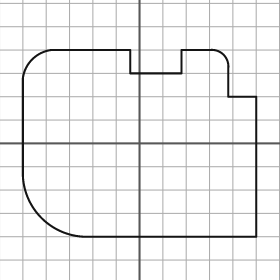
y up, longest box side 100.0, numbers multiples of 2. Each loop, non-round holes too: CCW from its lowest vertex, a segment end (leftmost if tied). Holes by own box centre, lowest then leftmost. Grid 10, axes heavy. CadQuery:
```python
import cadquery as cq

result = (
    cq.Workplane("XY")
    .moveTo(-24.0, -40.0)
    .lineTo(50.0, -40.0)
    .lineTo(50.0, 20.0)
    .lineTo(38.0, 20.0)
    .lineTo(38.0, 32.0)
    .threePointArc((36.0, 38.0), (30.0, 40.0))
    .lineTo(18.0, 40.0)
    .lineTo(18.0, 30.0)
    .lineTo(-4.0, 30.0)
    .lineTo(-4.0, 40.0)
    .lineTo(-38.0, 40.0)
    .threePointArc((-46.0, 36.0), (-50.0, 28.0))
    .lineTo(-50.0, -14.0)
    .threePointArc((-42.0, -32.0), (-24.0, -40.0))
    .close()
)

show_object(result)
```